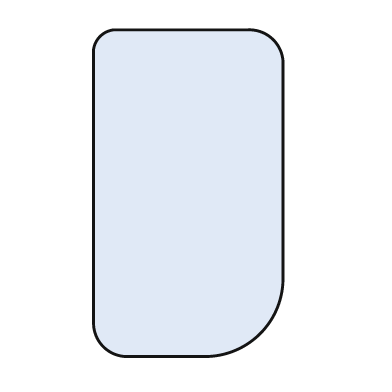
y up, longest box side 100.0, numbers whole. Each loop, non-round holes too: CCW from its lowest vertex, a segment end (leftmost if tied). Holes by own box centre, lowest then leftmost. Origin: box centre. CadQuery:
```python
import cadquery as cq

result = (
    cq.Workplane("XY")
    .moveTo(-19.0, -50.0)
    .lineTo(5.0, -50.0)
    .threePointArc((22.0, -43.0), (29.0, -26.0))
    .lineTo(29.0, 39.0)
    .threePointArc((26.0, 47.0), (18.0, 50.0))
    .lineTo(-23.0, 50.0)
    .threePointArc((-27.0, 48.0), (-29.0, 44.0))
    .lineTo(-29.0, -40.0)
    .threePointArc((-26.0, -47.0), (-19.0, -50.0))
    .close()
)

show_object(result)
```